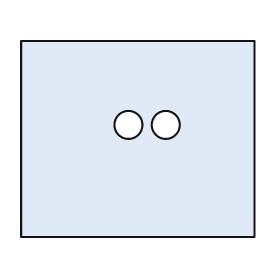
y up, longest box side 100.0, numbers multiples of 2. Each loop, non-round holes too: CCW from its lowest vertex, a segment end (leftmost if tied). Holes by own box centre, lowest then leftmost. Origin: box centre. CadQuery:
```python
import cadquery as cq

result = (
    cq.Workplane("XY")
    .moveTo(-50.0, -42.0)
    .lineTo(50.0, -42.0)
    .lineTo(50.0, 42.0)
    .lineTo(-50.0, 42.0)
    .close()
    .moveTo(-4.0, 6.0)
    .circle(6.0)
    .moveTo(12.0, 6.0)
    .circle(6.0)
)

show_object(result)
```